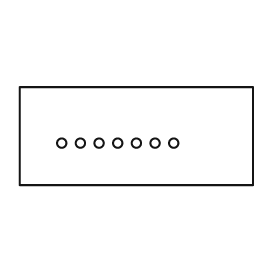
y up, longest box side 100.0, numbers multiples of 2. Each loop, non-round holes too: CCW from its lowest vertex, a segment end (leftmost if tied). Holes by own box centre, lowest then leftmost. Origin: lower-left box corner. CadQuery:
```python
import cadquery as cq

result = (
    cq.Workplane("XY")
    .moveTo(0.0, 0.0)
    .lineTo(100.0, 0.0)
    .lineTo(100.0, 42.0)
    .lineTo(0.0, 42.0)
    .close()
    .moveTo(18.0, 18.0)
    .circle(2.0)
    .moveTo(26.0, 18.0)
    .circle(2.0)
    .moveTo(34.0, 18.0)
    .circle(2.0)
    .moveTo(42.0, 18.0)
    .circle(2.0)
    .moveTo(50.0, 18.0)
    .circle(2.0)
    .moveTo(58.0, 18.0)
    .circle(2.0)
    .moveTo(66.0, 18.0)
    .circle(2.0)
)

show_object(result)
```